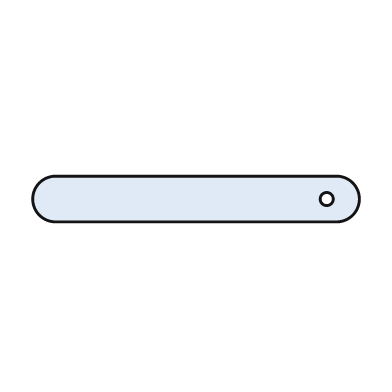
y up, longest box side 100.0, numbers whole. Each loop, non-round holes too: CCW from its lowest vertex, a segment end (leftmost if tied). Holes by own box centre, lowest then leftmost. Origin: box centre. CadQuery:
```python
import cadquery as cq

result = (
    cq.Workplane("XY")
    .moveTo(-43.0, -7.0)
    .lineTo(43.0, -7.0)
    .threePointArc((50.0, 0.0), (43.0, 7.0))
    .lineTo(-43.0, 7.0)
    .threePointArc((-50.0, 0.0), (-43.0, -7.0))
    .close()
    .moveTo(40.0, 0.0)
    .circle(2.0)
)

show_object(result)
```